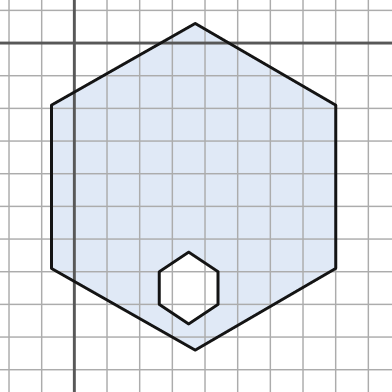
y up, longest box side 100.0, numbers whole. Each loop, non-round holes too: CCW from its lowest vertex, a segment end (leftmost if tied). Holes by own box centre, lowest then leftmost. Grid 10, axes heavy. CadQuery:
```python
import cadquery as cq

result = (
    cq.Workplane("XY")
    .moveTo(37.0, -94.0)
    .lineTo(80.0, -69.0)
    .lineTo(80.0, -19.0)
    .lineTo(37.0, 6.0)
    .lineTo(-7.0, -19.0)
    .lineTo(-7.0, -69.0)
    .close()
    .moveTo(35.0, -86.0)
    .lineTo(44.0, -80.0)
    .lineTo(44.0, -70.0)
    .lineTo(35.0, -64.0)
    .lineTo(26.0, -70.0)
    .lineTo(26.0, -80.0)
    .close()
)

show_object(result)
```